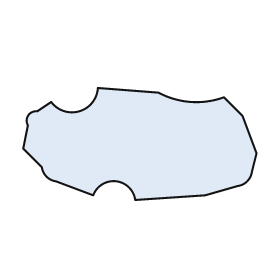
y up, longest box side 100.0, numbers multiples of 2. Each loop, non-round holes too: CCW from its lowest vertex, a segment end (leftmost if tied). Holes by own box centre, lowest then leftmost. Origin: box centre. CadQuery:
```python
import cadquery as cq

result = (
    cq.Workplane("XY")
    .moveTo(-2.0, -24.0)
    .lineTo(28.0, -22.0)
    .lineTo(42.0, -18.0)
    .threePointArc((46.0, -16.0), (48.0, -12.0))
    .lineTo(50.0, -4.0)
    .lineTo(44.0, 12.0)
    .lineTo(36.0, 20.0)
    .threePointArc((22.0, 18.0), (8.0, 22.0))
    .lineTo(-18.0, 24.0)
    .threePointArc((-26.0, 14.0), (-38.0, 18.0))
    .lineTo(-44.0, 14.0)
    .threePointArc((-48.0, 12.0), (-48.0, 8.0))
    .lineTo(-50.0, -2.0)
    .lineTo(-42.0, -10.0)
    .threePointArc((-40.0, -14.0), (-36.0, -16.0))
    .lineTo(-20.0, -22.0)
    .threePointArc((-10.0, -16.0), (-2.0, -24.0))
    .close()
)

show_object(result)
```